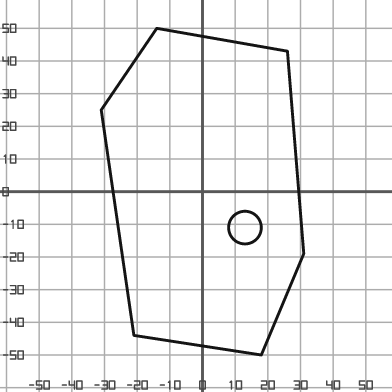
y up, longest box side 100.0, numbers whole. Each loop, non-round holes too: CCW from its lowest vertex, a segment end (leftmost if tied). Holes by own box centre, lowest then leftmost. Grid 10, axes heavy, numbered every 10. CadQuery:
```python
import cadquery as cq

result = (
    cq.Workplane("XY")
    .moveTo(18.0, -50.0)
    .lineTo(31.0, -19.0)
    .lineTo(26.0, 43.0)
    .lineTo(-14.0, 50.0)
    .lineTo(-31.0, 25.0)
    .lineTo(-21.0, -44.0)
    .close()
    .moveTo(13.0, -11.0)
    .circle(5.0)
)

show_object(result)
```